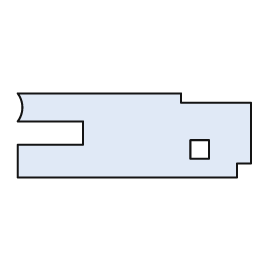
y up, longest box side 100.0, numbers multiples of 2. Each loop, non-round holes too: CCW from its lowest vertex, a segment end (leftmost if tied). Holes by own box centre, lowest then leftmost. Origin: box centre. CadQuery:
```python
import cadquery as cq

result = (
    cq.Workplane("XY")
    .moveTo(-50.0, -18.0)
    .lineTo(44.0, -18.0)
    .lineTo(44.0, -12.0)
    .lineTo(50.0, -12.0)
    .lineTo(50.0, 14.0)
    .lineTo(20.0, 14.0)
    .lineTo(20.0, 18.0)
    .lineTo(-50.0, 18.0)
    .threePointArc((-48.0, 12.0), (-50.0, 6.0))
    .lineTo(-22.0, 6.0)
    .lineTo(-22.0, -4.0)
    .lineTo(-50.0, -4.0)
    .close()
    .moveTo(24.0, -10.0)
    .lineTo(32.0, -10.0)
    .lineTo(32.0, -2.0)
    .lineTo(24.0, -2.0)
    .close()
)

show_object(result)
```